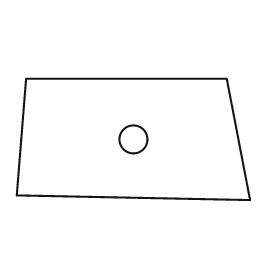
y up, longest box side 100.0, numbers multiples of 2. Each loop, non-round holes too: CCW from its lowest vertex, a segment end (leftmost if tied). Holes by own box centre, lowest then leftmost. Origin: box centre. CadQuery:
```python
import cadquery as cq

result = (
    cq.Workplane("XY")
    .moveTo(50.0, -26.0)
    .lineTo(40.0, 26.0)
    .lineTo(-46.0, 26.0)
    .lineTo(-50.0, -24.0)
    .close()
    .moveTo(0.0, 0.0)
    .circle(6.0)
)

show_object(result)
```